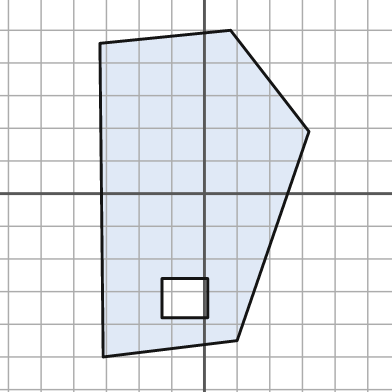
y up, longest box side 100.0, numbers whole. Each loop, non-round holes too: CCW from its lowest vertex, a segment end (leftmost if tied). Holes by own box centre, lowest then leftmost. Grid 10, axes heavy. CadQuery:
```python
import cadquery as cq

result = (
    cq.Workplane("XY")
    .moveTo(-31.0, -50.0)
    .lineTo(10.0, -45.0)
    .lineTo(32.0, 19.0)
    .lineTo(8.0, 50.0)
    .lineTo(-32.0, 46.0)
    .close()
    .moveTo(-13.0, -38.0)
    .lineTo(1.0, -38.0)
    .lineTo(1.0, -26.0)
    .lineTo(-13.0, -26.0)
    .close()
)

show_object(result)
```